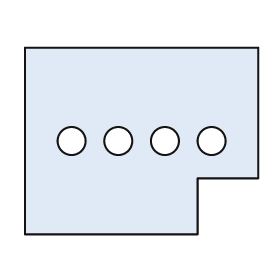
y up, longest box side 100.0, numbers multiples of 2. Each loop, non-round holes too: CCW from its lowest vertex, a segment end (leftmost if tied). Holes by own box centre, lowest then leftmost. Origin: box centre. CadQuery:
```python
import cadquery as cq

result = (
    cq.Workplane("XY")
    .moveTo(-50.0, -40.0)
    .lineTo(24.0, -40.0)
    .lineTo(24.0, -16.0)
    .lineTo(50.0, -16.0)
    .lineTo(50.0, 40.0)
    .lineTo(-50.0, 40.0)
    .close()
    .moveTo(-30.0, 0.0)
    .circle(6.0)
    .moveTo(-10.0, 0.0)
    .circle(6.0)
    .moveTo(10.0, 0.0)
    .circle(6.0)
    .moveTo(30.0, 0.0)
    .circle(6.0)
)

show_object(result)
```